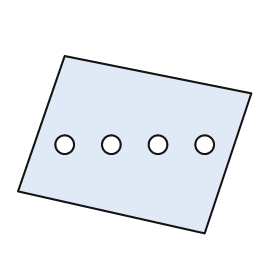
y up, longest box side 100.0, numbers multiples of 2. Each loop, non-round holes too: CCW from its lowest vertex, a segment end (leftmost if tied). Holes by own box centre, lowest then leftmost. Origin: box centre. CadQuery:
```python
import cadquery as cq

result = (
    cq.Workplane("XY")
    .moveTo(30.0, -38.0)
    .lineTo(50.0, 22.0)
    .lineTo(-30.0, 38.0)
    .lineTo(-50.0, -20.0)
    .close()
    .moveTo(-30.0, 0.0)
    .circle(4.0)
    .moveTo(-10.0, 0.0)
    .circle(4.0)
    .moveTo(10.0, 0.0)
    .circle(4.0)
    .moveTo(30.0, 0.0)
    .circle(4.0)
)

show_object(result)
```